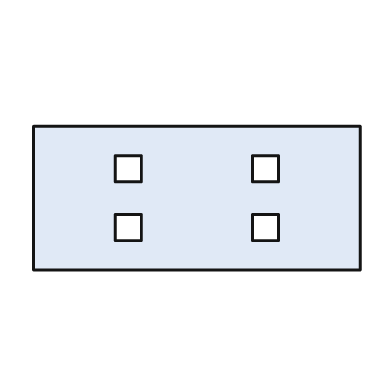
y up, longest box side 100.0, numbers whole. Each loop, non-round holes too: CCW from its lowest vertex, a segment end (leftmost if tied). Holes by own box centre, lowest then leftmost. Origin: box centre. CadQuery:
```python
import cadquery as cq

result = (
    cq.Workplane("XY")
    .moveTo(-50.0, -22.0)
    .lineTo(50.0, -22.0)
    .lineTo(50.0, 22.0)
    .lineTo(-50.0, 22.0)
    .close()
    .moveTo(-25.0, -13.0)
    .lineTo(-17.0, -13.0)
    .lineTo(-17.0, -5.0)
    .lineTo(-25.0, -5.0)
    .close()
    .moveTo(17.0, -13.0)
    .lineTo(25.0, -13.0)
    .lineTo(25.0, -5.0)
    .lineTo(17.0, -5.0)
    .close()
    .moveTo(-25.0, 5.0)
    .lineTo(-17.0, 5.0)
    .lineTo(-17.0, 13.0)
    .lineTo(-25.0, 13.0)
    .close()
    .moveTo(17.0, 5.0)
    .lineTo(25.0, 5.0)
    .lineTo(25.0, 13.0)
    .lineTo(17.0, 13.0)
    .close()
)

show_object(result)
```